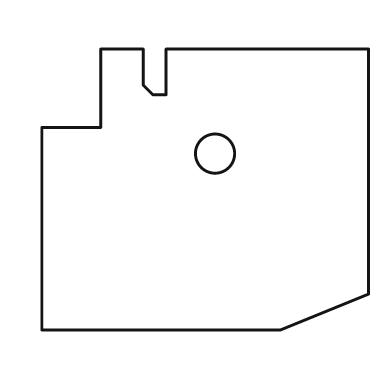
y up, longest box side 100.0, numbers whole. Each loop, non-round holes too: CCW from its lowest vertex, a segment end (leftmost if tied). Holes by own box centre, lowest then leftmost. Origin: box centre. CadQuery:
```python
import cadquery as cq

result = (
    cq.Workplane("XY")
    .moveTo(-50.0, -43.0)
    .lineTo(23.0, -43.0)
    .lineTo(50.0, -32.0)
    .lineTo(50.0, 43.0)
    .lineTo(-12.0, 43.0)
    .lineTo(-12.0, 29.0)
    .lineTo(-16.0, 29.0)
    .lineTo(-19.0, 32.0)
    .lineTo(-19.0, 43.0)
    .lineTo(-32.0, 43.0)
    .lineTo(-32.0, 19.0)
    .lineTo(-50.0, 19.0)
    .close()
    .moveTo(3.0, 11.0)
    .circle(6.0)
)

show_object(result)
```